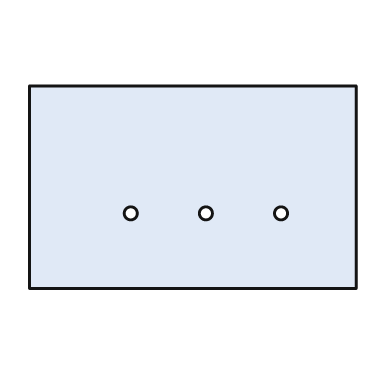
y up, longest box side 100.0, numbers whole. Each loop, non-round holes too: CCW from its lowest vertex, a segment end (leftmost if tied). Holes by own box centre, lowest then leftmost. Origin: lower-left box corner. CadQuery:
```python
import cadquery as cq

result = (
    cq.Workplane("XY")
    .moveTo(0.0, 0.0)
    .lineTo(100.0, 0.0)
    .lineTo(100.0, 62.0)
    .lineTo(0.0, 62.0)
    .close()
    .moveTo(31.0, 23.0)
    .circle(2.0)
    .moveTo(54.0, 23.0)
    .circle(2.0)
    .moveTo(77.0, 23.0)
    .circle(2.0)
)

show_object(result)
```